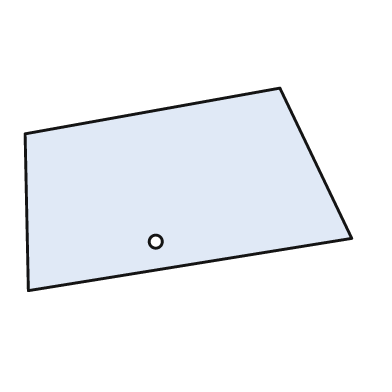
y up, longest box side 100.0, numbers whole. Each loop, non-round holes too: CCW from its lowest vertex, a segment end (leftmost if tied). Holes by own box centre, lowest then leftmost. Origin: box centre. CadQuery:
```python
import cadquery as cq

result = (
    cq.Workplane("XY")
    .moveTo(-49.0, -31.0)
    .lineTo(50.0, -15.0)
    .lineTo(28.0, 31.0)
    .lineTo(-50.0, 17.0)
    .close()
    .moveTo(-10.0, -16.0)
    .circle(2.0)
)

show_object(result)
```